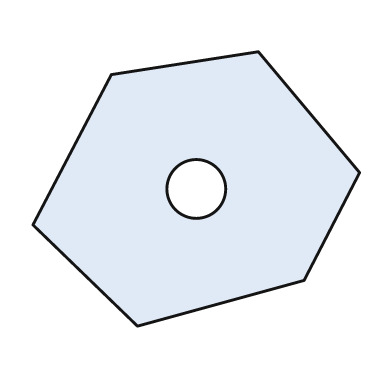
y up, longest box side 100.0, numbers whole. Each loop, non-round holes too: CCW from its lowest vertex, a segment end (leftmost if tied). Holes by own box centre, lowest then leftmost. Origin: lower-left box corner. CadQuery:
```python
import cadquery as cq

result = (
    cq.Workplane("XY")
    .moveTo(32.0, 0.0)
    .lineTo(83.0, 14.0)
    .lineTo(100.0, 47.0)
    .lineTo(69.0, 84.0)
    .lineTo(24.0, 77.0)
    .lineTo(0.0, 31.0)
    .close()
    .moveTo(50.0, 42.0)
    .circle(9.0)
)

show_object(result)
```